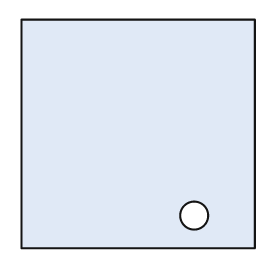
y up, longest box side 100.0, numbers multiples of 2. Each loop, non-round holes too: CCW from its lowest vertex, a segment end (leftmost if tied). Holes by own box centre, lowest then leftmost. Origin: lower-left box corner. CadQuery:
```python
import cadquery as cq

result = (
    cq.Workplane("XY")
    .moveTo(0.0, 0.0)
    .lineTo(100.0, 0.0)
    .lineTo(100.0, 98.0)
    .lineTo(0.0, 98.0)
    .close()
    .moveTo(74.0, 14.0)
    .circle(6.0)
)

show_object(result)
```